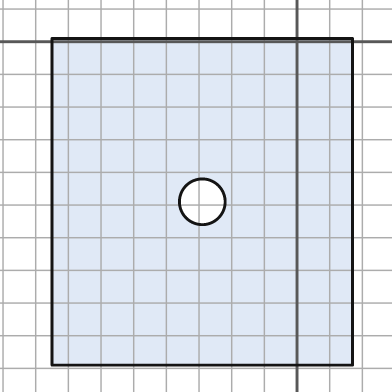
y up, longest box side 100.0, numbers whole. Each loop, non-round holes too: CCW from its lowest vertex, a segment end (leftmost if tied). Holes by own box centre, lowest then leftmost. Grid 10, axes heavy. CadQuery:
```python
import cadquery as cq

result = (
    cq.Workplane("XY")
    .moveTo(-75.0, -99.0)
    .lineTo(17.0, -99.0)
    .lineTo(17.0, 1.0)
    .lineTo(-75.0, 1.0)
    .close()
    .moveTo(-29.0, -49.0)
    .circle(7.0)
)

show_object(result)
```